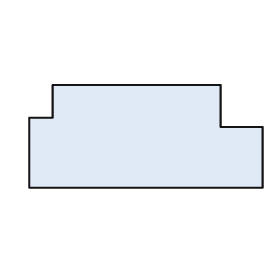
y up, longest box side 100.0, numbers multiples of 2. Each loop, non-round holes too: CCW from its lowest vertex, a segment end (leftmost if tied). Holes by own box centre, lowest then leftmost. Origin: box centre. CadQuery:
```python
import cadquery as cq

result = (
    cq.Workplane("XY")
    .moveTo(-50.0, -22.0)
    .lineTo(50.0, -22.0)
    .lineTo(50.0, 4.0)
    .lineTo(32.0, 4.0)
    .lineTo(32.0, 22.0)
    .lineTo(-40.0, 22.0)
    .lineTo(-40.0, 8.0)
    .lineTo(-50.0, 8.0)
    .close()
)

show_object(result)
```